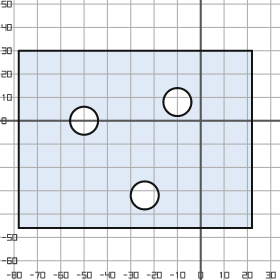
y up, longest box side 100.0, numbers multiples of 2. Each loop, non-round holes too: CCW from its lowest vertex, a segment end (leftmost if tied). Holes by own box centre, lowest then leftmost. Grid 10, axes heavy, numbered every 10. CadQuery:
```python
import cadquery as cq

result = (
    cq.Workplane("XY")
    .moveTo(-78.0, -46.0)
    .lineTo(22.0, -46.0)
    .lineTo(22.0, 30.0)
    .lineTo(-78.0, 30.0)
    .close()
    .moveTo(-24.0, -32.0)
    .circle(6.0)
    .moveTo(-50.0, 0.0)
    .circle(6.0)
    .moveTo(-10.0, 8.0)
    .circle(6.0)
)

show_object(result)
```